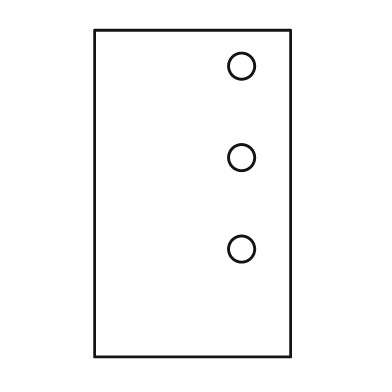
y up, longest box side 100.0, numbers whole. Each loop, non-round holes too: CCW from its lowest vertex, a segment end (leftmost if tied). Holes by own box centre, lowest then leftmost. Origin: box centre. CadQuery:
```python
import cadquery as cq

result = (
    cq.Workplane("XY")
    .moveTo(-30.0, -50.0)
    .lineTo(30.0, -50.0)
    .lineTo(30.0, 50.0)
    .lineTo(-30.0, 50.0)
    .close()
    .moveTo(15.0, -17.0)
    .circle(4.0)
    .moveTo(15.0, 11.0)
    .circle(4.0)
    .moveTo(15.0, 39.0)
    .circle(4.0)
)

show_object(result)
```